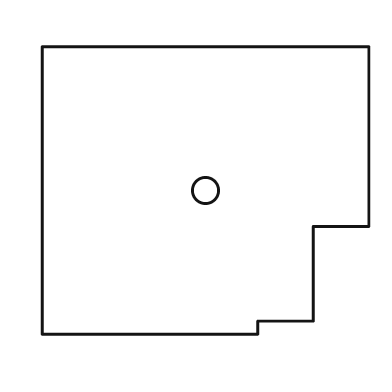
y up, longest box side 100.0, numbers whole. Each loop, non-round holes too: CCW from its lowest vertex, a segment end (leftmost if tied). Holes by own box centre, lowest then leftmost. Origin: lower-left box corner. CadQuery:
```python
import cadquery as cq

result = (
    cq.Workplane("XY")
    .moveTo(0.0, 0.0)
    .lineTo(66.0, 0.0)
    .lineTo(66.0, 4.0)
    .lineTo(83.0, 4.0)
    .lineTo(83.0, 33.0)
    .lineTo(100.0, 33.0)
    .lineTo(100.0, 88.0)
    .lineTo(0.0, 88.0)
    .close()
    .moveTo(50.0, 44.0)
    .circle(4.0)
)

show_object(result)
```